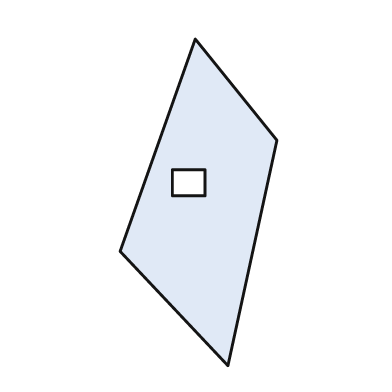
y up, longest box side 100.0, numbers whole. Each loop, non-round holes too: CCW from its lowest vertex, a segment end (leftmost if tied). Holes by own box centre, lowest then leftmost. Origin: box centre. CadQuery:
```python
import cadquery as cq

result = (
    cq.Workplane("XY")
    .moveTo(9.0, -50.0)
    .lineTo(24.0, 19.0)
    .lineTo(-1.0, 50.0)
    .lineTo(-24.0, -15.0)
    .close()
    .moveTo(-8.0, 2.0)
    .lineTo(2.0, 2.0)
    .lineTo(2.0, 10.0)
    .lineTo(-8.0, 10.0)
    .close()
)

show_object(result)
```